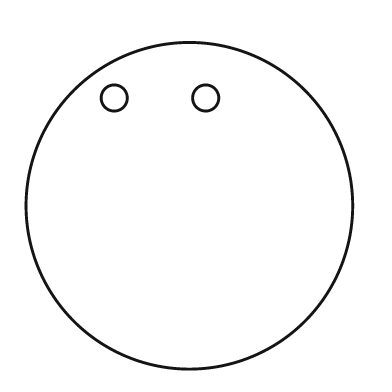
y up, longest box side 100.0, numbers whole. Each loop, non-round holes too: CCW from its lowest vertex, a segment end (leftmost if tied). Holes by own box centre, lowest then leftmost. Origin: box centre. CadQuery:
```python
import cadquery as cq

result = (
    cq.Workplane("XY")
    .moveTo(0.0, 0.0)
    .circle(50.0)
    .moveTo(-23.0, 33.0)
    .circle(4.0)
    .moveTo(5.0, 33.0)
    .circle(4.0)
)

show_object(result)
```